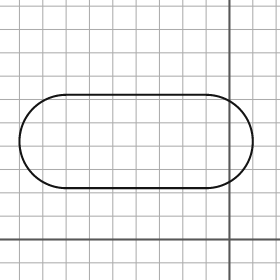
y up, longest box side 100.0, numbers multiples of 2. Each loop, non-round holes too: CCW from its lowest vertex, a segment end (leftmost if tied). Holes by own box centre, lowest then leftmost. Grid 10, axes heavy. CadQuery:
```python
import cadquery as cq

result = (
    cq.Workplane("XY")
    .moveTo(-70.0, 22.0)
    .lineTo(-10.0, 22.0)
    .threePointArc((10.0, 42.0), (-10.0, 62.0))
    .lineTo(-70.0, 62.0)
    .threePointArc((-90.0, 42.0), (-70.0, 22.0))
    .close()
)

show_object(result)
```